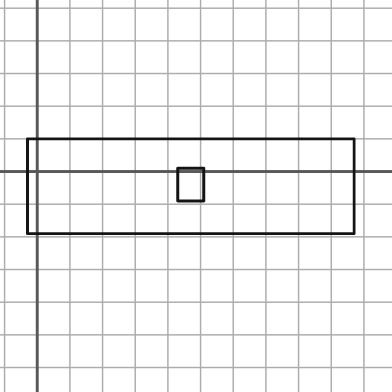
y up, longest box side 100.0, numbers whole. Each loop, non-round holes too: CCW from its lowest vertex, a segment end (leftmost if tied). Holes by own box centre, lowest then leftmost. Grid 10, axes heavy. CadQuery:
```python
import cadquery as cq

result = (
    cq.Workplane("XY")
    .moveTo(-3.0, -19.0)
    .lineTo(97.0, -19.0)
    .lineTo(97.0, 10.0)
    .lineTo(-3.0, 10.0)
    .close()
    .moveTo(43.0, -9.0)
    .lineTo(51.0, -9.0)
    .lineTo(51.0, 1.0)
    .lineTo(43.0, 1.0)
    .close()
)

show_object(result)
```